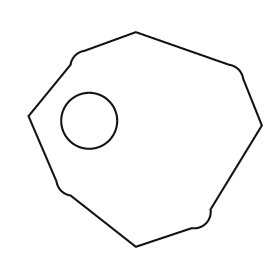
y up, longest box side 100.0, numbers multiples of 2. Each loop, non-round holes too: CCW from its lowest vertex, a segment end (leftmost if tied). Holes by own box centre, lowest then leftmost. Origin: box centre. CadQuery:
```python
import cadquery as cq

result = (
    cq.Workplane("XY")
    .moveTo(-4.0, -46.0)
    .lineTo(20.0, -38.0)
    .threePointArc((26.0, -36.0), (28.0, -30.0))
    .lineTo(50.0, 6.0)
    .lineTo(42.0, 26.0)
    .threePointArc((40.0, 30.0), (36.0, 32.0))
    .lineTo(-4.0, 46.0)
    .lineTo(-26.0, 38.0)
    .threePointArc((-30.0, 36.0), (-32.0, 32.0))
    .lineTo(-50.0, 10.0)
    .lineTo(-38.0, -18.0)
    .threePointArc((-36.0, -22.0), (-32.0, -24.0))
    .close()
    .moveTo(-24.0, 8.0)
    .circle(12.0)
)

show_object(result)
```